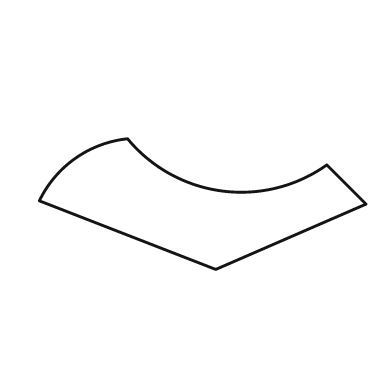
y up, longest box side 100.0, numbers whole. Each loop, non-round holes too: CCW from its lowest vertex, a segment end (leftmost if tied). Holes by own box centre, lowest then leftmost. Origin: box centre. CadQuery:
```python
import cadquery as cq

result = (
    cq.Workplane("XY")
    .moveTo(4.0, -20.0)
    .lineTo(50.0, 0.0)
    .lineTo(38.0, 12.0)
    .threePointArc((6.0, 4.0), (-23.0, 20.0))
    .threePointArc((-39.0, 14.0), (-50.0, 1.0))
    .close()
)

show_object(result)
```